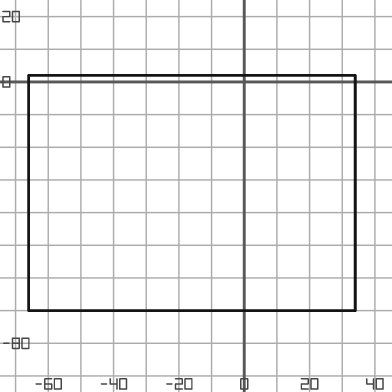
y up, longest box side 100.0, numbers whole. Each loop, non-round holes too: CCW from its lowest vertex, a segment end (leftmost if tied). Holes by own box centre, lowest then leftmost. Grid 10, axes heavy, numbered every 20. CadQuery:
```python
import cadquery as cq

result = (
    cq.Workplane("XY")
    .moveTo(-66.0, -70.0)
    .lineTo(34.0, -70.0)
    .lineTo(34.0, 2.0)
    .lineTo(-66.0, 2.0)
    .close()
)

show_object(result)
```